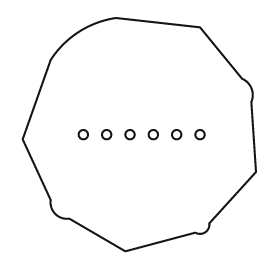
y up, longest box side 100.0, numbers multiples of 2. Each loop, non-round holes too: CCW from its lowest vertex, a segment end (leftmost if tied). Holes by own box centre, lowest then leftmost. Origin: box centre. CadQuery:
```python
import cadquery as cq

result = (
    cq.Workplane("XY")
    .moveTo(-6.0, -50.0)
    .lineTo(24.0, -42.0)
    .threePointArc((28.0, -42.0), (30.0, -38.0))
    .lineTo(50.0, -16.0)
    .lineTo(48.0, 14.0)
    .threePointArc((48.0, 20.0), (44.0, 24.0))
    .lineTo(26.0, 46.0)
    .lineTo(-10.0, 50.0)
    .threePointArc((-26.0, 44.0), (-38.0, 32.0))
    .lineTo(-50.0, -2.0)
    .lineTo(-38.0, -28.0)
    .threePointArc((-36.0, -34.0), (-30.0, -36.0))
    .close()
    .moveTo(-24.0, 0.0)
    .circle(2.0)
    .moveTo(-14.0, 0.0)
    .circle(2.0)
    .moveTo(-4.0, 0.0)
    .circle(2.0)
    .moveTo(6.0, 0.0)
    .circle(2.0)
    .moveTo(16.0, 0.0)
    .circle(2.0)
    .moveTo(26.0, 0.0)
    .circle(2.0)
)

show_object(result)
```